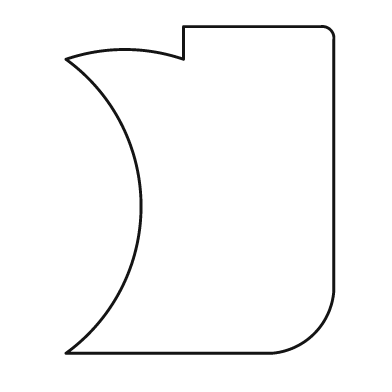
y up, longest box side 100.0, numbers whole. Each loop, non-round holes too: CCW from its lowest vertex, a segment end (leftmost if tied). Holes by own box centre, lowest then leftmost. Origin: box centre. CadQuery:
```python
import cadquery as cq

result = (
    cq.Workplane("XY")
    .moveTo(-41.0, -50.0)
    .lineTo(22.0, -50.0)
    .threePointArc((35.0, -44.0), (41.0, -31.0))
    .lineTo(41.0, 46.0)
    .threePointArc((40.0, 49.0), (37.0, 50.0))
    .lineTo(-5.0, 50.0)
    .lineTo(-5.0, 40.0)
    .threePointArc((-23.0, 43.0), (-41.0, 40.0))
    .threePointArc((-18.0, -5.0), (-41.0, -50.0))
    .close()
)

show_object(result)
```